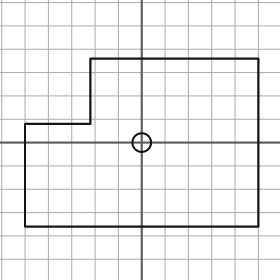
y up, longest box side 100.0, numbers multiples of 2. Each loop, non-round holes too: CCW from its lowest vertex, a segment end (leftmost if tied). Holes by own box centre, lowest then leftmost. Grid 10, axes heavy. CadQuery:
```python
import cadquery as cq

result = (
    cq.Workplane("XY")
    .moveTo(-50.0, -36.0)
    .lineTo(50.0, -36.0)
    .lineTo(50.0, 36.0)
    .lineTo(-22.0, 36.0)
    .lineTo(-22.0, 8.0)
    .lineTo(-50.0, 8.0)
    .close()
    .moveTo(0.0, 0.0)
    .circle(4.0)
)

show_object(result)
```